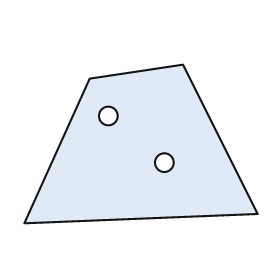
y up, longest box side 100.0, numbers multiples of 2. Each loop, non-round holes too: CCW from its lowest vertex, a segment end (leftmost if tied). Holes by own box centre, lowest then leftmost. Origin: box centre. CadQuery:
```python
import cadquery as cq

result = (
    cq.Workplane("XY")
    .moveTo(-50.0, -34.0)
    .lineTo(50.0, -30.0)
    .lineTo(18.0, 34.0)
    .lineTo(-22.0, 28.0)
    .close()
    .moveTo(10.0, -8.0)
    .circle(4.0)
    .moveTo(-14.0, 12.0)
    .circle(4.0)
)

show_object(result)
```